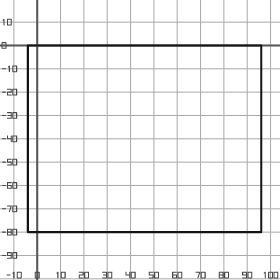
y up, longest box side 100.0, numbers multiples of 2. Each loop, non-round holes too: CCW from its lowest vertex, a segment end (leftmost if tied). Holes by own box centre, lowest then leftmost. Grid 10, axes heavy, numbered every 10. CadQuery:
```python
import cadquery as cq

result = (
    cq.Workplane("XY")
    .moveTo(-4.0, -80.0)
    .lineTo(96.0, -80.0)
    .lineTo(96.0, 0.0)
    .lineTo(-4.0, 0.0)
    .close()
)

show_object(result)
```